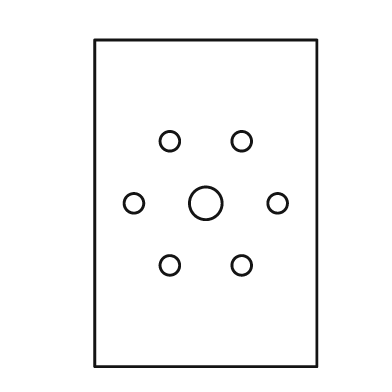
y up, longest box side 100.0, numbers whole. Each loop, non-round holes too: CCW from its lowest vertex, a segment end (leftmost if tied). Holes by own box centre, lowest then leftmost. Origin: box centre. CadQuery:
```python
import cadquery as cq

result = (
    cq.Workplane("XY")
    .moveTo(-34.0, -50.0)
    .lineTo(34.0, -50.0)
    .lineTo(34.0, 50.0)
    .lineTo(-34.0, 50.0)
    .close()
    .moveTo(-11.0, -19.0)
    .circle(3.0)
    .moveTo(11.0, -19.0)
    .circle(3.0)
    .moveTo(-22.0, 0.0)
    .circle(3.0)
    .moveTo(0.0, 0.0)
    .circle(5.0)
    .moveTo(22.0, 0.0)
    .circle(3.0)
    .moveTo(-11.0, 19.0)
    .circle(3.0)
    .moveTo(11.0, 19.0)
    .circle(3.0)
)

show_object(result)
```